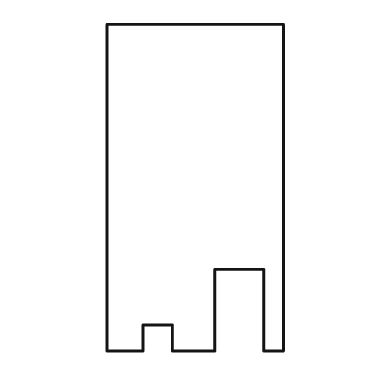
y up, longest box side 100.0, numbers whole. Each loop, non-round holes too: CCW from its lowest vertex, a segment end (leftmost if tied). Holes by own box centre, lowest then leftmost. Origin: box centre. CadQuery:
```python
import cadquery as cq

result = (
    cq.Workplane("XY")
    .moveTo(-27.0, -50.0)
    .lineTo(-16.0, -50.0)
    .lineTo(-16.0, -42.0)
    .lineTo(-7.0, -42.0)
    .lineTo(-7.0, -50.0)
    .lineTo(6.0, -50.0)
    .lineTo(6.0, -25.0)
    .lineTo(21.0, -25.0)
    .lineTo(21.0, -50.0)
    .lineTo(27.0, -50.0)
    .lineTo(27.0, 50.0)
    .lineTo(-27.0, 50.0)
    .close()
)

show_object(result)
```